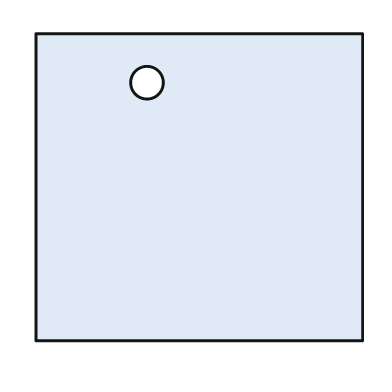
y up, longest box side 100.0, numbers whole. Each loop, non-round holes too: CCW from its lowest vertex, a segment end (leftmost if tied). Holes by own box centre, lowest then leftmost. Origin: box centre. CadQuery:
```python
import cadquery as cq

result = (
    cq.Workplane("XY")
    .moveTo(-50.0, -47.0)
    .lineTo(50.0, -47.0)
    .lineTo(50.0, 47.0)
    .lineTo(-50.0, 47.0)
    .close()
    .moveTo(-16.0, 32.0)
    .circle(5.0)
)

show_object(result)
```